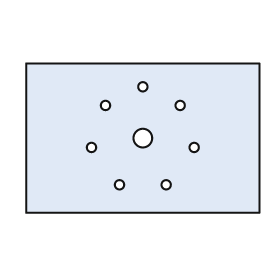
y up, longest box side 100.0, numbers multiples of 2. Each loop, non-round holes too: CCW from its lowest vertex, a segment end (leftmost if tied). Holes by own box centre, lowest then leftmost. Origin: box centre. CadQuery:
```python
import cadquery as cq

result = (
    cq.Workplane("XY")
    .moveTo(-50.0, -32.0)
    .lineTo(50.0, -32.0)
    .lineTo(50.0, 32.0)
    .lineTo(-50.0, 32.0)
    .close()
    .moveTo(-10.0, -20.0)
    .circle(2.0)
    .moveTo(10.0, -20.0)
    .circle(2.0)
    .moveTo(-22.0, -4.0)
    .circle(2.0)
    .moveTo(22.0, -4.0)
    .circle(2.0)
    .moveTo(0.0, 0.0)
    .circle(4.0)
    .moveTo(-16.0, 14.0)
    .circle(2.0)
    .moveTo(16.0, 14.0)
    .circle(2.0)
    .moveTo(0.0, 22.0)
    .circle(2.0)
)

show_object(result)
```